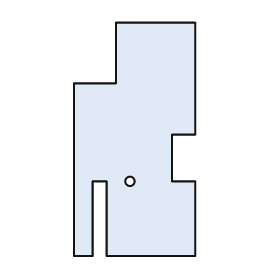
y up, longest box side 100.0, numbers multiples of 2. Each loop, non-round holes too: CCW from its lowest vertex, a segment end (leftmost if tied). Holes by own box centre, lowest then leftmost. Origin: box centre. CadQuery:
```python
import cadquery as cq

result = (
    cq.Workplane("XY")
    .moveTo(-26.0, -50.0)
    .lineTo(-18.0, -50.0)
    .lineTo(-18.0, -18.0)
    .lineTo(-12.0, -18.0)
    .lineTo(-12.0, -50.0)
    .lineTo(26.0, -50.0)
    .lineTo(26.0, -18.0)
    .lineTo(16.0, -18.0)
    .lineTo(16.0, 2.0)
    .lineTo(26.0, 2.0)
    .lineTo(26.0, 50.0)
    .lineTo(-8.0, 50.0)
    .lineTo(-8.0, 24.0)
    .lineTo(-26.0, 24.0)
    .close()
    .moveTo(-2.0, -18.0)
    .circle(2.0)
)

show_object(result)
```